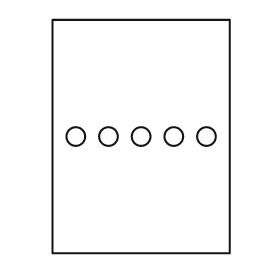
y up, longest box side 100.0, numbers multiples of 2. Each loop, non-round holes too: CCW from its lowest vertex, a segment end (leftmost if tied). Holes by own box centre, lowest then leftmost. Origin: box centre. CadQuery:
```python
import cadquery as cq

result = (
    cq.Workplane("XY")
    .moveTo(-38.0, -50.0)
    .lineTo(38.0, -50.0)
    .lineTo(38.0, 50.0)
    .lineTo(-38.0, 50.0)
    .close()
    .moveTo(-28.0, 0.0)
    .circle(4.0)
    .moveTo(-14.0, 0.0)
    .circle(4.0)
    .moveTo(0.0, 0.0)
    .circle(4.0)
    .moveTo(14.0, 0.0)
    .circle(4.0)
    .moveTo(28.0, 0.0)
    .circle(4.0)
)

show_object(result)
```